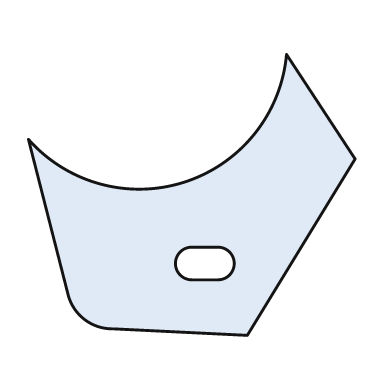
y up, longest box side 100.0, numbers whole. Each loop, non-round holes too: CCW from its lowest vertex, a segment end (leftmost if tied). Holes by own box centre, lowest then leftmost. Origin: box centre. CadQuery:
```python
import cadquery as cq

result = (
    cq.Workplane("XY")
    .moveTo(17.0, -43.0)
    .lineTo(50.0, 11.0)
    .lineTo(29.0, 43.0)
    .threePointArc((-2.0, 4.0), (-50.0, 17.0))
    .lineTo(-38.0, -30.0)
    .threePointArc((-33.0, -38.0), (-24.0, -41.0))
    .close()
    .moveTo(0.0, -26.0)
    .lineTo(8.0, -26.0)
    .threePointArc((13.0, -21.0), (8.0, -16.0))
    .lineTo(0.0, -16.0)
    .threePointArc((-5.0, -21.0), (0.0, -26.0))
    .close()
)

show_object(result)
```